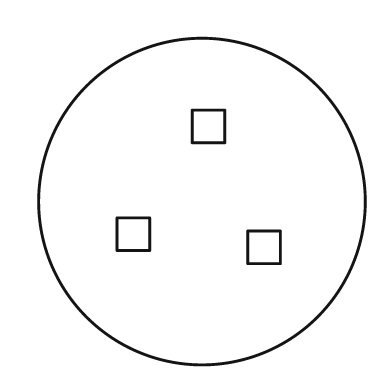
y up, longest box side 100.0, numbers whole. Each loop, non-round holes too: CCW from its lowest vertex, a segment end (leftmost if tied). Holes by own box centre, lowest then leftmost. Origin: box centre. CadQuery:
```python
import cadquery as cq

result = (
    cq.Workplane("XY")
    .moveTo(0.0, 0.0)
    .circle(50.0)
    .moveTo(14.0, -19.0)
    .lineTo(24.0, -19.0)
    .lineTo(24.0, -9.0)
    .lineTo(14.0, -9.0)
    .close()
    .moveTo(-26.0, -15.0)
    .lineTo(-16.0, -15.0)
    .lineTo(-16.0, -5.0)
    .lineTo(-26.0, -5.0)
    .close()
    .moveTo(-3.0, 18.0)
    .lineTo(7.0, 18.0)
    .lineTo(7.0, 28.0)
    .lineTo(-3.0, 28.0)
    .close()
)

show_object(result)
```